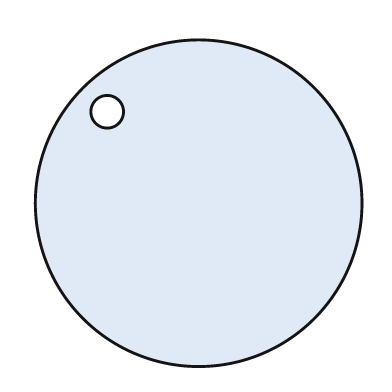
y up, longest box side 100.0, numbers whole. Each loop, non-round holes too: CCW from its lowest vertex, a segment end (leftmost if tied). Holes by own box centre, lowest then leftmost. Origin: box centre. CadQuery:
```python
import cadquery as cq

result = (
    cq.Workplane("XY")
    .moveTo(0.0, 0.0)
    .circle(50.0)
    .moveTo(-28.0, 28.0)
    .circle(5.0)
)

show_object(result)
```